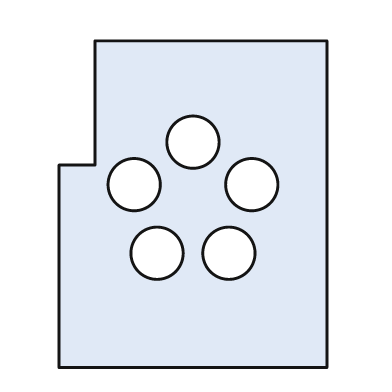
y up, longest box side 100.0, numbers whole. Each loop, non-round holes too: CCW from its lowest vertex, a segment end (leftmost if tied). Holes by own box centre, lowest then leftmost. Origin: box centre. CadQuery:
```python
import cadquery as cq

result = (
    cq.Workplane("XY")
    .moveTo(-41.0, -50.0)
    .lineTo(41.0, -50.0)
    .lineTo(41.0, 50.0)
    .lineTo(-30.0, 50.0)
    .lineTo(-30.0, 12.0)
    .lineTo(-41.0, 12.0)
    .close()
    .moveTo(-11.0, -15.0)
    .circle(8.0)
    .moveTo(11.0, -15.0)
    .circle(8.0)
    .moveTo(-18.0, 6.0)
    .circle(8.0)
    .moveTo(18.0, 6.0)
    .circle(8.0)
    .moveTo(0.0, 19.0)
    .circle(8.0)
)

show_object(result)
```